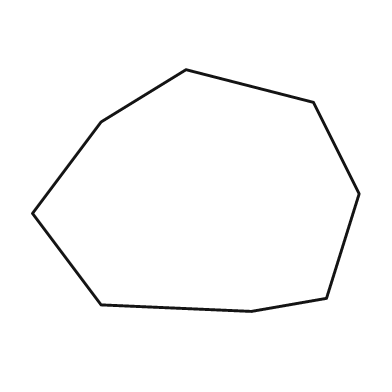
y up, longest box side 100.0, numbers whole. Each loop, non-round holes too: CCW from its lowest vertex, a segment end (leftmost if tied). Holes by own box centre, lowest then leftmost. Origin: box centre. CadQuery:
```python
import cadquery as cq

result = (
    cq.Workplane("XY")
    .moveTo(17.0, -37.0)
    .lineTo(40.0, -33.0)
    .lineTo(50.0, -1.0)
    .lineTo(36.0, 27.0)
    .lineTo(-3.0, 37.0)
    .lineTo(-29.0, 21.0)
    .lineTo(-50.0, -7.0)
    .lineTo(-29.0, -35.0)
    .close()
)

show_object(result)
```